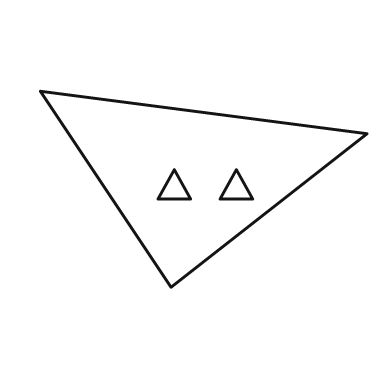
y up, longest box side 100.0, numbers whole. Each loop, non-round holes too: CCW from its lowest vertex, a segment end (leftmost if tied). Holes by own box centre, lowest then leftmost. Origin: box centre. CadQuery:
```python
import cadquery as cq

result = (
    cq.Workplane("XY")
    .moveTo(-10.0, -30.0)
    .lineTo(50.0, 17.0)
    .lineTo(-50.0, 30.0)
    .close()
    .moveTo(-14.0, -3.0)
    .lineTo(-4.0, -3.0)
    .lineTo(-9.0, 6.0)
    .close()
    .moveTo(5.0, -3.0)
    .lineTo(15.0, -3.0)
    .lineTo(10.0, 6.0)
    .close()
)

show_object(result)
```